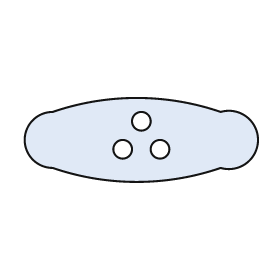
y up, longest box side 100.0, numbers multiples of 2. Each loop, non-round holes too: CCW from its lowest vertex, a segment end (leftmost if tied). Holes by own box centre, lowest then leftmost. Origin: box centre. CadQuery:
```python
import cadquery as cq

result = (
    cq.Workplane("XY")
    .moveTo(-38.0, -12.0)
    .threePointArc((-2.0, -18.0), (34.0, -12.0))
    .threePointArc((50.0, 0.0), (34.0, 12.0))
    .threePointArc((-2.0, 18.0), (-38.0, 12.0))
    .threePointArc((-50.0, 0.0), (-38.0, -12.0))
    .close()
    .moveTo(-8.0, -4.0)
    .circle(4.0)
    .moveTo(8.0, -4.0)
    .circle(4.0)
    .moveTo(0.0, 8.0)
    .circle(4.0)
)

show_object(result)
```